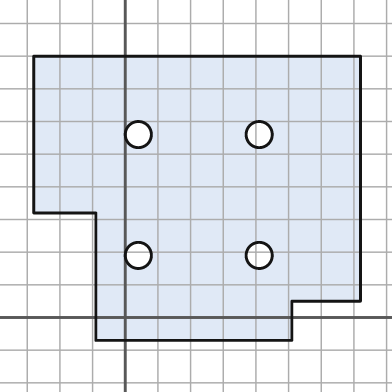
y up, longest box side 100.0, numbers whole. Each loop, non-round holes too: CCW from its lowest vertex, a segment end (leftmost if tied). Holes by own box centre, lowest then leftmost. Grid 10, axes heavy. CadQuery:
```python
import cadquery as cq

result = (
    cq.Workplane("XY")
    .moveTo(-9.0, -7.0)
    .lineTo(51.0, -7.0)
    .lineTo(51.0, 5.0)
    .lineTo(72.0, 5.0)
    .lineTo(72.0, 80.0)
    .lineTo(-28.0, 80.0)
    .lineTo(-28.0, 32.0)
    .lineTo(-9.0, 32.0)
    .close()
    .moveTo(4.0, 19.0)
    .circle(4.0)
    .moveTo(41.0, 19.0)
    .circle(4.0)
    .moveTo(4.0, 56.0)
    .circle(4.0)
    .moveTo(41.0, 56.0)
    .circle(4.0)
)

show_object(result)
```